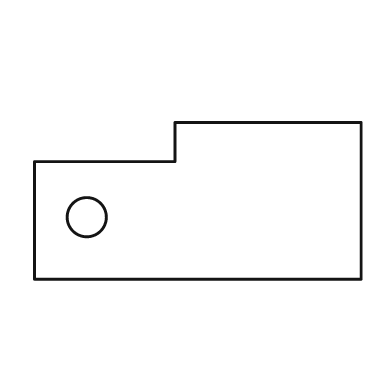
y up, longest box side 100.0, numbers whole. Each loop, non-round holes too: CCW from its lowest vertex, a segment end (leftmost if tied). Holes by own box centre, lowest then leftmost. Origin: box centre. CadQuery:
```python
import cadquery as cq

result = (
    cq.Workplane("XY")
    .moveTo(-50.0, -24.0)
    .lineTo(50.0, -24.0)
    .lineTo(50.0, 24.0)
    .lineTo(-7.0, 24.0)
    .lineTo(-7.0, 12.0)
    .lineTo(-50.0, 12.0)
    .close()
    .moveTo(-34.0, -5.0)
    .circle(6.0)
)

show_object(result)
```